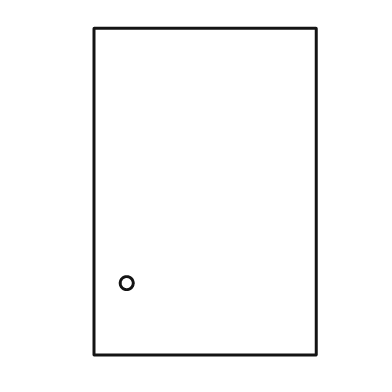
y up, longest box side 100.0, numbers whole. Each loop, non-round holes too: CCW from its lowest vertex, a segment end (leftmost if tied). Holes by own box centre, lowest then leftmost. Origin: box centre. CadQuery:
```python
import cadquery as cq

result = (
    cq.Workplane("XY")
    .moveTo(-34.0, -50.0)
    .lineTo(34.0, -50.0)
    .lineTo(34.0, 50.0)
    .lineTo(-34.0, 50.0)
    .close()
    .moveTo(-24.0, -28.0)
    .circle(2.0)
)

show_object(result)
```